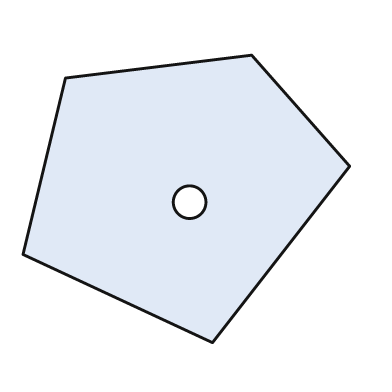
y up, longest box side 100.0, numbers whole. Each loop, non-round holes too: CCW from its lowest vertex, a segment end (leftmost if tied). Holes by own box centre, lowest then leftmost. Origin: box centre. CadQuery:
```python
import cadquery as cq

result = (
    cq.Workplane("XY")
    .moveTo(8.0, -44.0)
    .lineTo(50.0, 10.0)
    .lineTo(20.0, 44.0)
    .lineTo(-37.0, 37.0)
    .lineTo(-50.0, -17.0)
    .close()
    .moveTo(1.0, -1.0)
    .circle(5.0)
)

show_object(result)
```